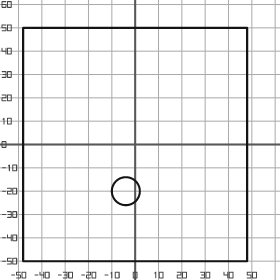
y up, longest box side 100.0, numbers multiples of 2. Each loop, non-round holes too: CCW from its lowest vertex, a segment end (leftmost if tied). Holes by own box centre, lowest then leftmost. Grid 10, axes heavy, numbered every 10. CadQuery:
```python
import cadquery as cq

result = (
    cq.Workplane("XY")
    .moveTo(-48.0, -50.0)
    .lineTo(48.0, -50.0)
    .lineTo(48.0, 50.0)
    .lineTo(-48.0, 50.0)
    .close()
    .moveTo(-4.0, -20.0)
    .circle(6.0)
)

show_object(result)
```